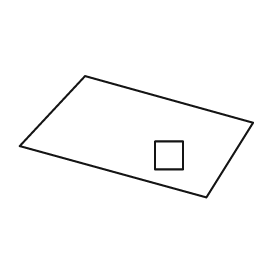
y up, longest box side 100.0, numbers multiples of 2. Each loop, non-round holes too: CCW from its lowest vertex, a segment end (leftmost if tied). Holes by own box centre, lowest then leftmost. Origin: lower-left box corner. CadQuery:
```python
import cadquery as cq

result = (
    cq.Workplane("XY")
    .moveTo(80.0, 0.0)
    .lineTo(100.0, 32.0)
    .lineTo(28.0, 52.0)
    .lineTo(0.0, 22.0)
    .close()
    .moveTo(58.0, 12.0)
    .lineTo(70.0, 12.0)
    .lineTo(70.0, 24.0)
    .lineTo(58.0, 24.0)
    .close()
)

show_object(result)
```